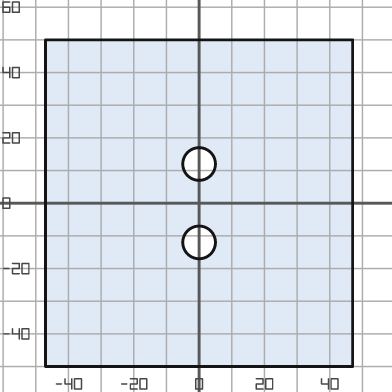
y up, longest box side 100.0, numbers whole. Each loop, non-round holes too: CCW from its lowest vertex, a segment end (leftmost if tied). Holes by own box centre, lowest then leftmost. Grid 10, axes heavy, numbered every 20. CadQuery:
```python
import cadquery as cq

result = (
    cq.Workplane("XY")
    .moveTo(-47.0, -50.0)
    .lineTo(47.0, -50.0)
    .lineTo(47.0, 50.0)
    .lineTo(-47.0, 50.0)
    .close()
    .moveTo(0.0, -12.0)
    .circle(5.0)
    .moveTo(0.0, 12.0)
    .circle(5.0)
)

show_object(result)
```